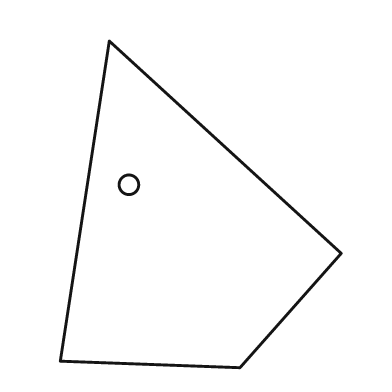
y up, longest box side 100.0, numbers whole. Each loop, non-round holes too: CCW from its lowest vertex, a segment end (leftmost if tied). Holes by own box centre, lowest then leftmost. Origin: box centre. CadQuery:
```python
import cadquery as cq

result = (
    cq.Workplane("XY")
    .moveTo(12.0, -50.0)
    .lineTo(43.0, -15.0)
    .lineTo(-28.0, 50.0)
    .lineTo(-43.0, -48.0)
    .close()
    .moveTo(-22.0, 6.0)
    .circle(3.0)
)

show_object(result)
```